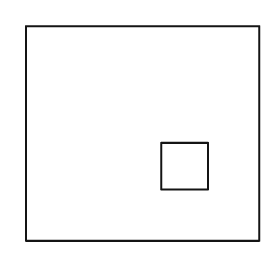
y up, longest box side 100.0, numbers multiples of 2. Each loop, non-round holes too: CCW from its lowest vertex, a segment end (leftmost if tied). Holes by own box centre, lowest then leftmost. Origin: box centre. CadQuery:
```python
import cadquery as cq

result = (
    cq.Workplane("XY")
    .moveTo(-50.0, -46.0)
    .lineTo(50.0, -46.0)
    .lineTo(50.0, 46.0)
    .lineTo(-50.0, 46.0)
    .close()
    .moveTo(8.0, -24.0)
    .lineTo(28.0, -24.0)
    .lineTo(28.0, -4.0)
    .lineTo(8.0, -4.0)
    .close()
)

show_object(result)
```